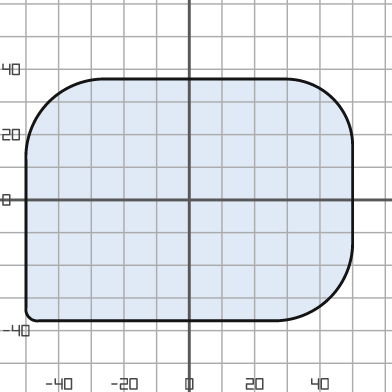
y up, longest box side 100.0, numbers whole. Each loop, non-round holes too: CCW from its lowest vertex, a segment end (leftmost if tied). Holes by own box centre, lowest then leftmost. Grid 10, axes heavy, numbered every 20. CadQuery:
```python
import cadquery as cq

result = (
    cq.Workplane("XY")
    .moveTo(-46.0, -37.0)
    .lineTo(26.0, -37.0)
    .threePointArc((43.0, -30.0), (50.0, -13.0))
    .lineTo(50.0, 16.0)
    .threePointArc((44.0, 31.0), (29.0, 37.0))
    .lineTo(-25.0, 37.0)
    .threePointArc((-43.0, 30.0), (-50.0, 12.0))
    .lineTo(-50.0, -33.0)
    .threePointArc((-49.0, -36.0), (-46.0, -37.0))
    .close()
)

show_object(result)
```